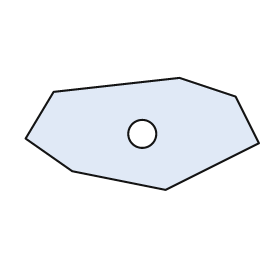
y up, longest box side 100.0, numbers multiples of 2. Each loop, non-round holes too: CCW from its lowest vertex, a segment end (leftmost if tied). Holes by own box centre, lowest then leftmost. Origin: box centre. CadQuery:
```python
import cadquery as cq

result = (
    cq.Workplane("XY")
    .moveTo(10.0, -24.0)
    .lineTo(50.0, -4.0)
    .lineTo(40.0, 16.0)
    .lineTo(16.0, 24.0)
    .lineTo(-38.0, 18.0)
    .lineTo(-50.0, -2.0)
    .lineTo(-30.0, -16.0)
    .close()
    .moveTo(0.0, 0.0)
    .circle(6.0)
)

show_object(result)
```